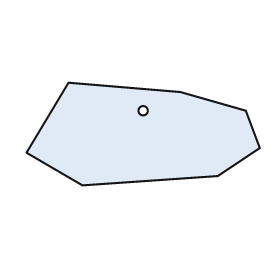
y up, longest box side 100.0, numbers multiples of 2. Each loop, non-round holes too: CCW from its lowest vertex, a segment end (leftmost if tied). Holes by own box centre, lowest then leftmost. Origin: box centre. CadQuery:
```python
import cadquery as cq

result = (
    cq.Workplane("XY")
    .moveTo(-26.0, -22.0)
    .lineTo(32.0, -18.0)
    .lineTo(50.0, -6.0)
    .lineTo(44.0, 10.0)
    .lineTo(16.0, 18.0)
    .lineTo(-32.0, 22.0)
    .lineTo(-50.0, -8.0)
    .close()
    .moveTo(0.0, 10.0)
    .circle(2.0)
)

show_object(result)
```